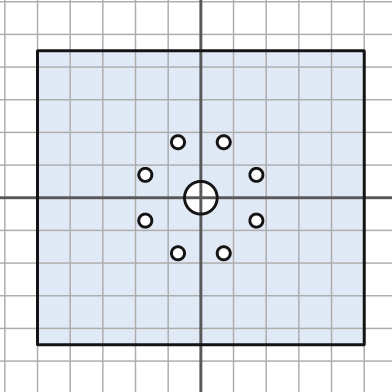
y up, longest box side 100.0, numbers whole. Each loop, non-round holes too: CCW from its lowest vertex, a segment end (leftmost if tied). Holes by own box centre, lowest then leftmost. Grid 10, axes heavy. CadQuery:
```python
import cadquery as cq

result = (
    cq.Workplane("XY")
    .moveTo(-50.0, -45.0)
    .lineTo(50.0, -45.0)
    .lineTo(50.0, 45.0)
    .lineTo(-50.0, 45.0)
    .close()
    .moveTo(-7.0, -17.0)
    .circle(2.0)
    .moveTo(7.0, -17.0)
    .circle(2.0)
    .moveTo(-17.0, -7.0)
    .circle(2.0)
    .moveTo(17.0, -7.0)
    .circle(2.0)
    .moveTo(0.0, 0.0)
    .circle(5.0)
    .moveTo(-17.0, 7.0)
    .circle(2.0)
    .moveTo(17.0, 7.0)
    .circle(2.0)
    .moveTo(-7.0, 17.0)
    .circle(2.0)
    .moveTo(7.0, 17.0)
    .circle(2.0)
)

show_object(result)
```